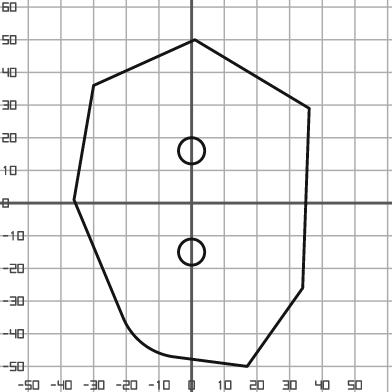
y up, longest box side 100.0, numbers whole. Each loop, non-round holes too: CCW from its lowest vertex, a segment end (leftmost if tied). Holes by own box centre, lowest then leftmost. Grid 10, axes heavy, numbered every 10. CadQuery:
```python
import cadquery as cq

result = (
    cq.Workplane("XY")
    .moveTo(17.0, -50.0)
    .lineTo(34.0, -26.0)
    .lineTo(36.0, 29.0)
    .lineTo(1.0, 50.0)
    .lineTo(-30.0, 36.0)
    .lineTo(-36.0, 1.0)
    .lineTo(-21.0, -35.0)
    .threePointArc((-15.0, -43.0), (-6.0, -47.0))
    .close()
    .moveTo(0.0, -15.0)
    .circle(4.0)
    .moveTo(0.0, 16.0)
    .circle(4.0)
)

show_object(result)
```